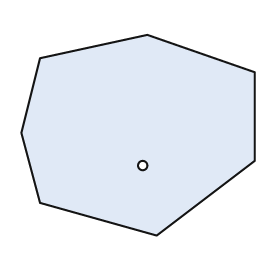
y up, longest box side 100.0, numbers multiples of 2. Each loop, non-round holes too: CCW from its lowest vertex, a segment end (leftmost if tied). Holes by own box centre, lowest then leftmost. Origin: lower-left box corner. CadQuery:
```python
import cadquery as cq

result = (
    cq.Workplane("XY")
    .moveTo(58.0, 0.0)
    .lineTo(100.0, 32.0)
    .lineTo(100.0, 70.0)
    .lineTo(54.0, 86.0)
    .lineTo(8.0, 76.0)
    .lineTo(0.0, 44.0)
    .lineTo(8.0, 14.0)
    .close()
    .moveTo(52.0, 30.0)
    .circle(2.0)
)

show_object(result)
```